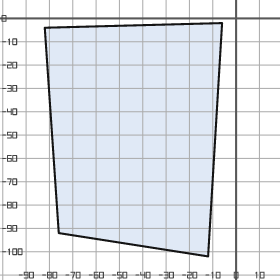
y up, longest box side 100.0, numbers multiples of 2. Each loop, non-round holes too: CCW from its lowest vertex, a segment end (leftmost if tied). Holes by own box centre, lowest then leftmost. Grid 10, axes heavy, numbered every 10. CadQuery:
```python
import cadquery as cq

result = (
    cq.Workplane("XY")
    .moveTo(-12.0, -102.0)
    .lineTo(-6.0, -2.0)
    .lineTo(-82.0, -4.0)
    .lineTo(-76.0, -92.0)
    .close()
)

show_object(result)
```